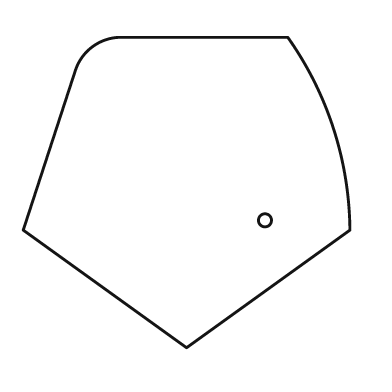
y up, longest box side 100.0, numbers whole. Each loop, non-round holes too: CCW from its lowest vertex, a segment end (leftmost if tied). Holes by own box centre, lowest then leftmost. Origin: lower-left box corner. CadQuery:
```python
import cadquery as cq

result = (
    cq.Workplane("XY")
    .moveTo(50.0, 0.0)
    .lineTo(100.0, 36.0)
    .threePointArc((95.0, 67.0), (81.0, 95.0))
    .lineTo(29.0, 95.0)
    .threePointArc((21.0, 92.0), (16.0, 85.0))
    .lineTo(0.0, 36.0)
    .close()
    .moveTo(74.0, 39.0)
    .circle(2.0)
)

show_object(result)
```